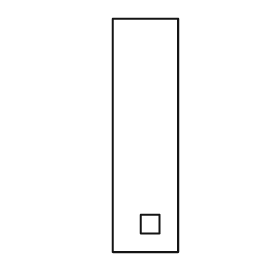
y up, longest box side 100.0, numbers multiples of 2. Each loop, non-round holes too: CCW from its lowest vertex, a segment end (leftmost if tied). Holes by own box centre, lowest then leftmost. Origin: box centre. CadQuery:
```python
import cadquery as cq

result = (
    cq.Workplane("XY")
    .moveTo(-14.0, -50.0)
    .lineTo(14.0, -50.0)
    .lineTo(14.0, 50.0)
    .lineTo(-14.0, 50.0)
    .close()
    .moveTo(-2.0, -42.0)
    .lineTo(6.0, -42.0)
    .lineTo(6.0, -34.0)
    .lineTo(-2.0, -34.0)
    .close()
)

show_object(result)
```